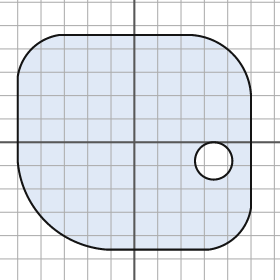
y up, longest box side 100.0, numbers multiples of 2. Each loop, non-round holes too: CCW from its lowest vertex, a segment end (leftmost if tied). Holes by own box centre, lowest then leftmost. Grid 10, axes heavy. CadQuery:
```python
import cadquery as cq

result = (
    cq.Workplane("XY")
    .moveTo(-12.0, -46.0)
    .lineTo(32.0, -46.0)
    .threePointArc((44.0, -40.0), (50.0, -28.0))
    .lineTo(50.0, 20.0)
    .threePointArc((42.0, 38.0), (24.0, 46.0))
    .lineTo(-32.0, 46.0)
    .threePointArc((-44.0, 40.0), (-50.0, 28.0))
    .lineTo(-50.0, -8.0)
    .threePointArc((-38.0, -34.0), (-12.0, -46.0))
    .close()
    .moveTo(34.0, -8.0)
    .circle(8.0)
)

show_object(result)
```